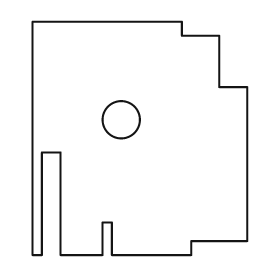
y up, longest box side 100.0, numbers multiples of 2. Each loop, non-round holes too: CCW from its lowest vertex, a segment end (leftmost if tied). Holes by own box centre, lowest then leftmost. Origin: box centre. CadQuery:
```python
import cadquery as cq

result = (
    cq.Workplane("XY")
    .moveTo(-46.0, -50.0)
    .lineTo(-42.0, -50.0)
    .lineTo(-42.0, -6.0)
    .lineTo(-34.0, -6.0)
    .lineTo(-34.0, -50.0)
    .lineTo(-16.0, -50.0)
    .lineTo(-16.0, -36.0)
    .lineTo(-12.0, -36.0)
    .lineTo(-12.0, -50.0)
    .lineTo(22.0, -50.0)
    .lineTo(22.0, -44.0)
    .lineTo(46.0, -44.0)
    .lineTo(46.0, 22.0)
    .lineTo(34.0, 22.0)
    .lineTo(34.0, 44.0)
    .lineTo(18.0, 44.0)
    .lineTo(18.0, 50.0)
    .lineTo(-46.0, 50.0)
    .close()
    .moveTo(-8.0, 8.0)
    .circle(8.0)
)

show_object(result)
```